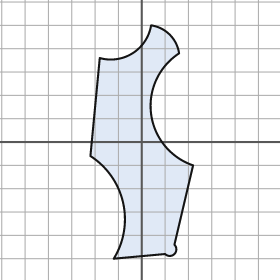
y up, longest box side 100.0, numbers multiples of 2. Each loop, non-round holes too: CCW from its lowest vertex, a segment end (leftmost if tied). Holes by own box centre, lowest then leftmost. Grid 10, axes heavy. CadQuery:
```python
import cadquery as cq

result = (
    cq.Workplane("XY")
    .moveTo(-12.0, -50.0)
    .lineTo(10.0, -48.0)
    .threePointArc((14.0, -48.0), (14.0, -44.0))
    .lineTo(22.0, -10.0)
    .threePointArc((4.0, 12.0), (16.0, 38.0))
    .threePointArc((12.0, 46.0), (4.0, 50.0))
    .threePointArc((-4.0, 38.0), (-18.0, 36.0))
    .lineTo(-22.0, -6.0)
    .threePointArc((-8.0, -26.0), (-12.0, -50.0))
    .close()
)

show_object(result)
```